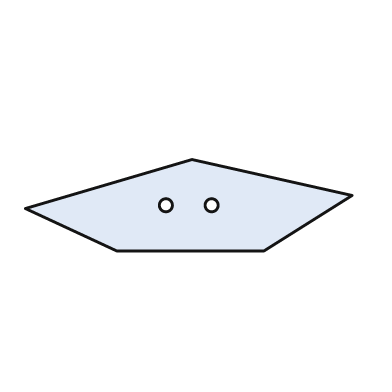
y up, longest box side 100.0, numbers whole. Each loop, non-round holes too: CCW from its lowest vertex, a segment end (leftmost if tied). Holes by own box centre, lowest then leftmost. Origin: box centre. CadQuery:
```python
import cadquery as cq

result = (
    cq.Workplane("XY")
    .moveTo(-22.0, -14.0)
    .lineTo(23.0, -14.0)
    .lineTo(50.0, 3.0)
    .lineTo(1.0, 14.0)
    .lineTo(-50.0, -1.0)
    .close()
    .moveTo(-7.0, 0.0)
    .circle(2.0)
    .moveTo(7.0, 0.0)
    .circle(2.0)
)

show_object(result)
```